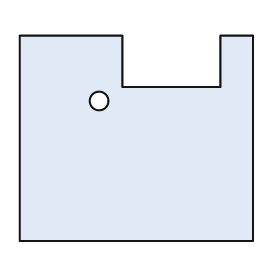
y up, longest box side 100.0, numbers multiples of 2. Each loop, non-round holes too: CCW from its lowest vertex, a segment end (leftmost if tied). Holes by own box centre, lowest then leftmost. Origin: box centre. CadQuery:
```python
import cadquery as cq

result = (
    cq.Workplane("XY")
    .moveTo(-50.0, -44.0)
    .lineTo(50.0, -44.0)
    .lineTo(50.0, 44.0)
    .lineTo(36.0, 44.0)
    .lineTo(36.0, 22.0)
    .lineTo(-6.0, 22.0)
    .lineTo(-6.0, 44.0)
    .lineTo(-50.0, 44.0)
    .close()
    .moveTo(-16.0, 16.0)
    .circle(4.0)
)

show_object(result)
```